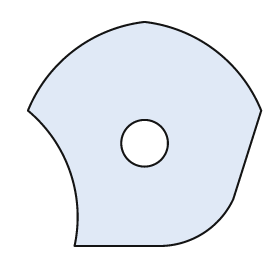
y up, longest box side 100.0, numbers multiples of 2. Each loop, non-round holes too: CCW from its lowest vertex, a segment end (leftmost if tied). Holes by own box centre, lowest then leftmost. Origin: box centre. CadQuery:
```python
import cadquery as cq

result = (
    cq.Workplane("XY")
    .moveTo(-30.0, -48.0)
    .lineTo(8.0, -48.0)
    .threePointArc((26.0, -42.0), (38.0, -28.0))
    .lineTo(50.0, 10.0)
    .threePointArc((30.0, 36.0), (0.0, 48.0))
    .threePointArc((-30.0, 36.0), (-50.0, 10.0))
    .threePointArc((-32.0, -16.0), (-30.0, -48.0))
    .close()
    .moveTo(0.0, -4.0)
    .circle(10.0)
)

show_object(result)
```